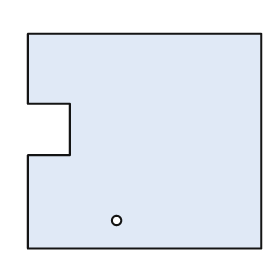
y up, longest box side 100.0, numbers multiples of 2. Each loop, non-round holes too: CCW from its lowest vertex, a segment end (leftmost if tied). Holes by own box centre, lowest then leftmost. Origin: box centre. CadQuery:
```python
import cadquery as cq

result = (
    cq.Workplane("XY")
    .moveTo(-50.0, -46.0)
    .lineTo(50.0, -46.0)
    .lineTo(50.0, 46.0)
    .lineTo(-50.0, 46.0)
    .lineTo(-50.0, 16.0)
    .lineTo(-32.0, 16.0)
    .lineTo(-32.0, -6.0)
    .lineTo(-50.0, -6.0)
    .close()
    .moveTo(-12.0, -34.0)
    .circle(2.0)
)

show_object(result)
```